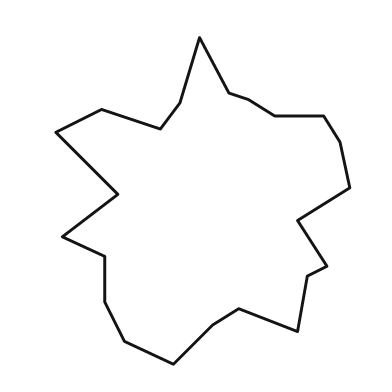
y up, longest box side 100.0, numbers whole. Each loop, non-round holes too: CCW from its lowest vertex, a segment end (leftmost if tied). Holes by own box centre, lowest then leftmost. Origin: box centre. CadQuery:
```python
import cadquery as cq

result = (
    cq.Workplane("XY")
    .moveTo(-9.0, -50.0)
    .lineTo(3.0, -38.0)
    .lineTo(11.0, -33.0)
    .lineTo(29.0, -40.0)
    .lineTo(32.0, -23.0)
    .lineTo(38.0, -20.0)
    .lineTo(29.0, -6.0)
    .lineTo(45.0, 4.0)
    .lineTo(42.0, 18.0)
    .lineTo(37.0, 26.0)
    .lineTo(22.0, 26.0)
    .lineTo(14.0, 31.0)
    .lineTo(8.0, 33.0)
    .lineTo(-1.0, 50.0)
    .lineTo(-7.0, 30.0)
    .lineTo(-13.0, 22.0)
    .lineTo(-31.0, 28.0)
    .lineTo(-45.0, 21.0)
    .lineTo(-26.0, 2.0)
    .lineTo(-43.0, -11.0)
    .lineTo(-30.0, -17.0)
    .lineTo(-30.0, -31.0)
    .lineTo(-24.0, -43.0)
    .close()
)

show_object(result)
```